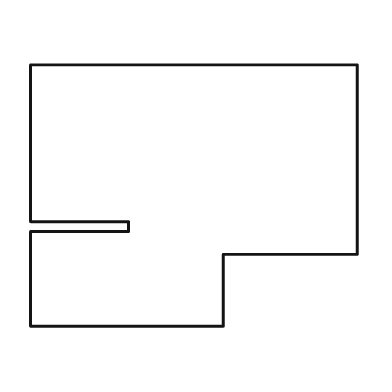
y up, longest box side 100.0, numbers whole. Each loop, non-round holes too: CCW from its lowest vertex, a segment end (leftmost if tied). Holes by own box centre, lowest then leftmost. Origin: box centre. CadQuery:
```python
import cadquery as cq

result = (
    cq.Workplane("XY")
    .moveTo(-50.0, -40.0)
    .lineTo(9.0, -40.0)
    .lineTo(9.0, -18.0)
    .lineTo(50.0, -18.0)
    .lineTo(50.0, 40.0)
    .lineTo(-50.0, 40.0)
    .lineTo(-50.0, -8.0)
    .lineTo(-20.0, -8.0)
    .lineTo(-20.0, -11.0)
    .lineTo(-50.0, -11.0)
    .close()
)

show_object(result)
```